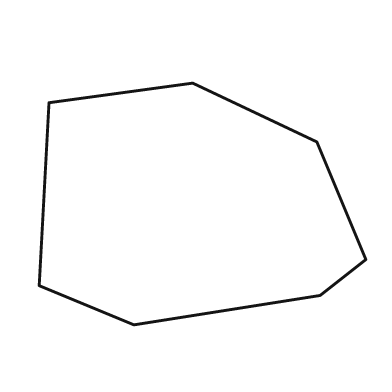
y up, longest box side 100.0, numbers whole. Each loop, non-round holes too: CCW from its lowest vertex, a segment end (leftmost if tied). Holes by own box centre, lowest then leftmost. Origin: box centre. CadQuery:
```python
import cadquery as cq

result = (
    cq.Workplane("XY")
    .moveTo(-21.0, -37.0)
    .lineTo(36.0, -28.0)
    .lineTo(50.0, -17.0)
    .lineTo(35.0, 19.0)
    .lineTo(-3.0, 37.0)
    .lineTo(-47.0, 31.0)
    .lineTo(-50.0, -25.0)
    .close()
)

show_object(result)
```